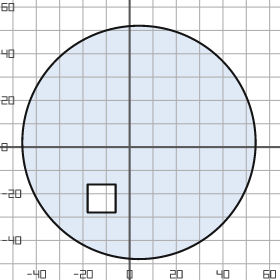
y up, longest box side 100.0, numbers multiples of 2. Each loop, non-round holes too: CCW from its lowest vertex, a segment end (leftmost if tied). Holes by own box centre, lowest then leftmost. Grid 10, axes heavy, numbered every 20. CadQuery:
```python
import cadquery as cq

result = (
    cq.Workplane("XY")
    .moveTo(4.0, 2.0)
    .circle(50.0)
    .moveTo(-18.0, -28.0)
    .lineTo(-6.0, -28.0)
    .lineTo(-6.0, -16.0)
    .lineTo(-18.0, -16.0)
    .close()
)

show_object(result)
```